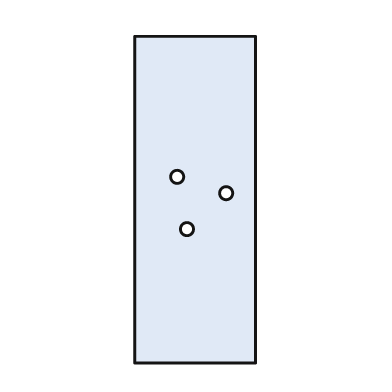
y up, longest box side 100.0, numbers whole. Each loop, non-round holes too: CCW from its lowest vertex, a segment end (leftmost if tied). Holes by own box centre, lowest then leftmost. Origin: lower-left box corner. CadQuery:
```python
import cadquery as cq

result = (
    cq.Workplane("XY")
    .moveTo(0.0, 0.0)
    .lineTo(37.0, 0.0)
    .lineTo(37.0, 100.0)
    .lineTo(0.0, 100.0)
    .close()
    .moveTo(16.0, 41.0)
    .circle(2.0)
    .moveTo(28.0, 52.0)
    .circle(2.0)
    .moveTo(13.0, 57.0)
    .circle(2.0)
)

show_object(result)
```